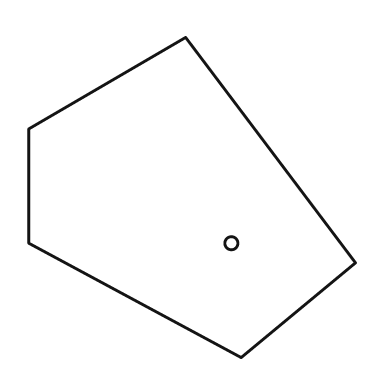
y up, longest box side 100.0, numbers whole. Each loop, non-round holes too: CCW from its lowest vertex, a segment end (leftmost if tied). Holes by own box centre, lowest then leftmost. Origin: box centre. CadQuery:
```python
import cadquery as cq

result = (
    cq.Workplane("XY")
    .moveTo(15.0, -49.0)
    .lineTo(50.0, -20.0)
    .lineTo(-2.0, 49.0)
    .lineTo(-50.0, 21.0)
    .lineTo(-50.0, -14.0)
    .close()
    .moveTo(12.0, -14.0)
    .circle(2.0)
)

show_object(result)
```